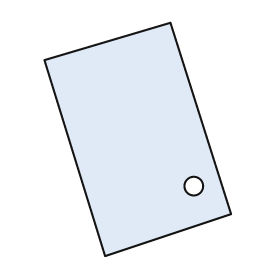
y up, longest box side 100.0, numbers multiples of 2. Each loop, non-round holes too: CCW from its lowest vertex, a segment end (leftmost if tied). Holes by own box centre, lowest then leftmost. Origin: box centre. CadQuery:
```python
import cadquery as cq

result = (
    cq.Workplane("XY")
    .moveTo(-14.0, -50.0)
    .lineTo(40.0, -32.0)
    .lineTo(14.0, 50.0)
    .lineTo(-40.0, 34.0)
    .close()
    .moveTo(24.0, -20.0)
    .circle(4.0)
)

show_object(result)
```